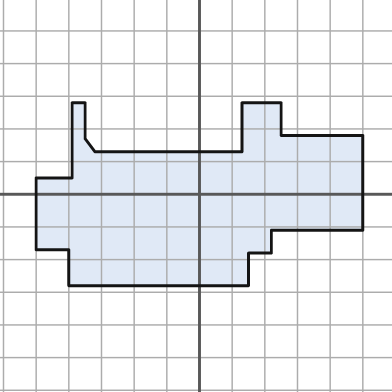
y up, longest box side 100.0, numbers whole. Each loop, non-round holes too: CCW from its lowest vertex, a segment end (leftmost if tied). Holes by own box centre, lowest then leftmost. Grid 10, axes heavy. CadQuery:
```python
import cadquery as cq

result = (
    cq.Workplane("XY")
    .moveTo(-40.0, -28.0)
    .lineTo(15.0, -28.0)
    .lineTo(15.0, -18.0)
    .lineTo(22.0, -18.0)
    .lineTo(22.0, -11.0)
    .lineTo(50.0, -11.0)
    .lineTo(50.0, 18.0)
    .lineTo(25.0, 18.0)
    .lineTo(25.0, 28.0)
    .lineTo(13.0, 28.0)
    .lineTo(13.0, 13.0)
    .lineTo(-32.0, 13.0)
    .lineTo(-35.0, 17.0)
    .lineTo(-35.0, 28.0)
    .lineTo(-39.0, 28.0)
    .lineTo(-39.0, 5.0)
    .lineTo(-50.0, 5.0)
    .lineTo(-50.0, -17.0)
    .lineTo(-40.0, -17.0)
    .close()
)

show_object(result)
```